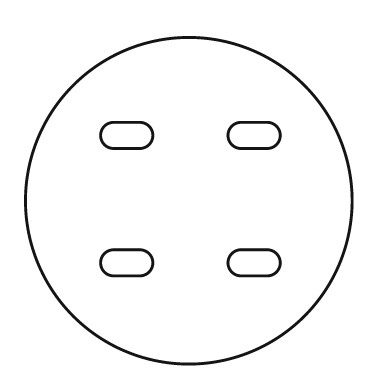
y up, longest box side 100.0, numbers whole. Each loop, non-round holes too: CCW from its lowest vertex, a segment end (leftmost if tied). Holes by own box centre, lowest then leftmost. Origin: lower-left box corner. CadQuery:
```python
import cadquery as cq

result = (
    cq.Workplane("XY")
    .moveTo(50.0, 50.0)
    .circle(50.0)
    .moveTo(27.0, 27.0)
    .lineTo(35.0, 27.0)
    .threePointArc((39.0, 31.0), (35.0, 35.0))
    .lineTo(27.0, 35.0)
    .threePointArc((23.0, 31.0), (27.0, 27.0))
    .close()
    .moveTo(66.0, 27.0)
    .lineTo(74.0, 27.0)
    .threePointArc((78.0, 31.0), (74.0, 35.0))
    .lineTo(66.0, 35.0)
    .threePointArc((62.0, 31.0), (66.0, 27.0))
    .close()
    .moveTo(27.0, 66.0)
    .lineTo(35.0, 66.0)
    .threePointArc((39.0, 70.0), (35.0, 74.0))
    .lineTo(27.0, 74.0)
    .threePointArc((23.0, 70.0), (27.0, 66.0))
    .close()
    .moveTo(66.0, 66.0)
    .lineTo(74.0, 66.0)
    .threePointArc((78.0, 70.0), (74.0, 74.0))
    .lineTo(66.0, 74.0)
    .threePointArc((62.0, 70.0), (66.0, 66.0))
    .close()
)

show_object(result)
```